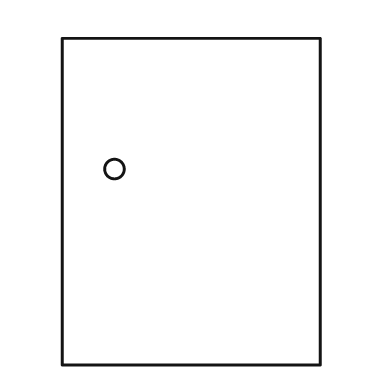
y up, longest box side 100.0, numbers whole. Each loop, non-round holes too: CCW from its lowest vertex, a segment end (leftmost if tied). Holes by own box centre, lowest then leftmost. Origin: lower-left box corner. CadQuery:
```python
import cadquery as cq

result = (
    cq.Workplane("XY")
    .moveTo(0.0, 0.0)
    .lineTo(79.0, 0.0)
    .lineTo(79.0, 100.0)
    .lineTo(0.0, 100.0)
    .close()
    .moveTo(16.0, 60.0)
    .circle(3.0)
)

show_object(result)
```